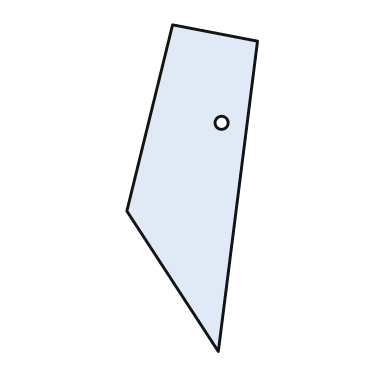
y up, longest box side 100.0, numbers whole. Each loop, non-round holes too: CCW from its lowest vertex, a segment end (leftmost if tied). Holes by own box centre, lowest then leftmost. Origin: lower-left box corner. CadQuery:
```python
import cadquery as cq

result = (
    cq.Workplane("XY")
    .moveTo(28.0, 0.0)
    .lineTo(40.0, 95.0)
    .lineTo(14.0, 100.0)
    .lineTo(0.0, 43.0)
    .close()
    .moveTo(29.0, 70.0)
    .circle(2.0)
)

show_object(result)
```